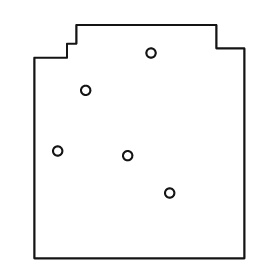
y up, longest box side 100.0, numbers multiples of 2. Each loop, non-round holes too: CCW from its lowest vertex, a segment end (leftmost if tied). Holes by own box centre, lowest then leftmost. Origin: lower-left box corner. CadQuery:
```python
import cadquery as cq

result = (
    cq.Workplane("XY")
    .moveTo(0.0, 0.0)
    .lineTo(90.0, 0.0)
    .lineTo(90.0, 90.0)
    .lineTo(78.0, 90.0)
    .lineTo(78.0, 100.0)
    .lineTo(18.0, 100.0)
    .lineTo(18.0, 92.0)
    .lineTo(14.0, 92.0)
    .lineTo(14.0, 86.0)
    .lineTo(0.0, 86.0)
    .close()
    .moveTo(58.0, 28.0)
    .circle(2.0)
    .moveTo(40.0, 44.0)
    .circle(2.0)
    .moveTo(10.0, 46.0)
    .circle(2.0)
    .moveTo(22.0, 72.0)
    .circle(2.0)
    .moveTo(50.0, 88.0)
    .circle(2.0)
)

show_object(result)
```